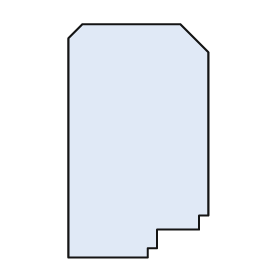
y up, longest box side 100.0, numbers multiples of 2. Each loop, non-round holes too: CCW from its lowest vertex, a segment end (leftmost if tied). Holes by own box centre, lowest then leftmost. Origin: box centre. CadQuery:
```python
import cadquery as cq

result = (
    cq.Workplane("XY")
    .moveTo(-30.0, -50.0)
    .lineTo(4.0, -50.0)
    .lineTo(4.0, -46.0)
    .lineTo(8.0, -46.0)
    .lineTo(8.0, -38.0)
    .lineTo(26.0, -38.0)
    .lineTo(26.0, -32.0)
    .lineTo(30.0, -32.0)
    .lineTo(30.0, 38.0)
    .lineTo(18.0, 50.0)
    .lineTo(-24.0, 50.0)
    .lineTo(-30.0, 44.0)
    .close()
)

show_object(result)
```